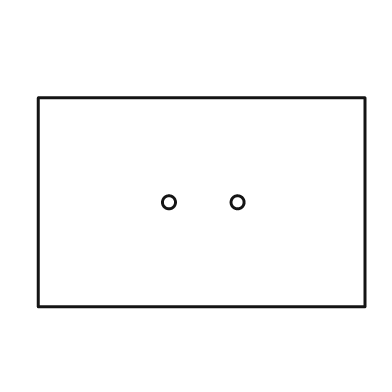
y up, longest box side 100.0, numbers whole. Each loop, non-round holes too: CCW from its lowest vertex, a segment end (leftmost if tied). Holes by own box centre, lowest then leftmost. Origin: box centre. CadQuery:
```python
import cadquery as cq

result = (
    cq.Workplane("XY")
    .moveTo(-50.0, -32.0)
    .lineTo(50.0, -32.0)
    .lineTo(50.0, 32.0)
    .lineTo(-50.0, 32.0)
    .close()
    .moveTo(-10.0, 0.0)
    .circle(2.0)
    .moveTo(11.0, 0.0)
    .circle(2.0)
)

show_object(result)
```